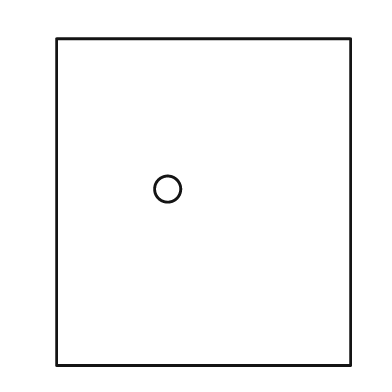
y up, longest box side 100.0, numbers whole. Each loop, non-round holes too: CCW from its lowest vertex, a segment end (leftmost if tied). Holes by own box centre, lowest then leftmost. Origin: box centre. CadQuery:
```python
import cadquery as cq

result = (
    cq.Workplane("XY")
    .moveTo(-45.0, -50.0)
    .lineTo(45.0, -50.0)
    .lineTo(45.0, 50.0)
    .lineTo(-45.0, 50.0)
    .close()
    .moveTo(-11.0, 4.0)
    .circle(4.0)
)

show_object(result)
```